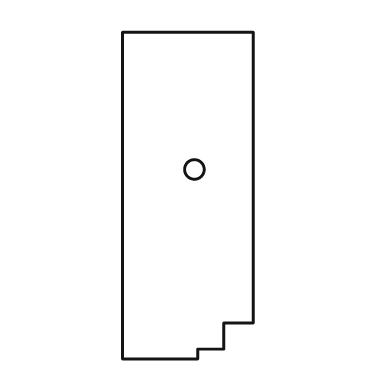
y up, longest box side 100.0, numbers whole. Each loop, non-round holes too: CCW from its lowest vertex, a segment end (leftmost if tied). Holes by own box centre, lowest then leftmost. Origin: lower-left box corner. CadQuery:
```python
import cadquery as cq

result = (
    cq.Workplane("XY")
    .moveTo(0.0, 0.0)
    .lineTo(23.0, 0.0)
    .lineTo(23.0, 3.0)
    .lineTo(31.0, 3.0)
    .lineTo(31.0, 11.0)
    .lineTo(40.0, 11.0)
    .lineTo(40.0, 100.0)
    .lineTo(0.0, 100.0)
    .close()
    .moveTo(22.0, 58.0)
    .circle(3.0)
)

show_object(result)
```